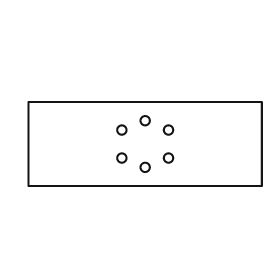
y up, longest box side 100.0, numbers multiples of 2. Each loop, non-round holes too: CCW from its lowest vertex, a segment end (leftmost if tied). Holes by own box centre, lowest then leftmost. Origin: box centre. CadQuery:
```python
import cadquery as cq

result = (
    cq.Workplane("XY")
    .moveTo(-50.0, -18.0)
    .lineTo(50.0, -18.0)
    .lineTo(50.0, 18.0)
    .lineTo(-50.0, 18.0)
    .close()
    .moveTo(0.0, -10.0)
    .circle(2.0)
    .moveTo(-10.0, -6.0)
    .circle(2.0)
    .moveTo(10.0, -6.0)
    .circle(2.0)
    .moveTo(-10.0, 6.0)
    .circle(2.0)
    .moveTo(10.0, 6.0)
    .circle(2.0)
    .moveTo(0.0, 10.0)
    .circle(2.0)
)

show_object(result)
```